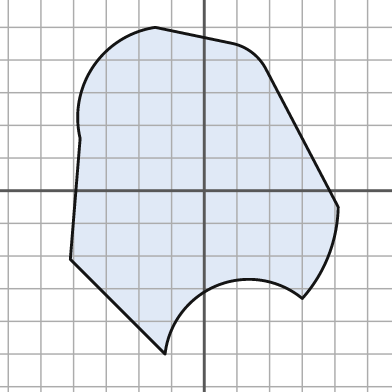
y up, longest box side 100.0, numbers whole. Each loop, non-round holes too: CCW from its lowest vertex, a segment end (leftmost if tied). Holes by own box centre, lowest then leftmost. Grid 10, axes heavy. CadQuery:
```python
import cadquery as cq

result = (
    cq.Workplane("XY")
    .moveTo(-12.0, -50.0)
    .threePointArc((4.0, -29.0), (30.0, -33.0))
    .threePointArc((38.0, -20.0), (41.0, -5.0))
    .lineTo(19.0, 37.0)
    .threePointArc((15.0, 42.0), (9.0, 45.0))
    .lineTo(-15.0, 50.0)
    .threePointArc((-34.0, 38.0), (-38.0, 16.0))
    .lineTo(-41.0, -21.0)
    .close()
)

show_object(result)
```